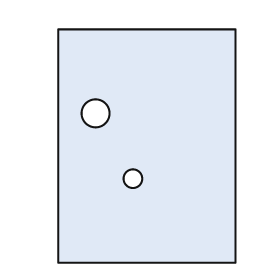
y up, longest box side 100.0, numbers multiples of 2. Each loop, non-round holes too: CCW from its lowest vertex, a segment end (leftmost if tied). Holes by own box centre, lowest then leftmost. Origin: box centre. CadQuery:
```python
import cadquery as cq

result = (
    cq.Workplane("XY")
    .moveTo(-38.0, -50.0)
    .lineTo(38.0, -50.0)
    .lineTo(38.0, 50.0)
    .lineTo(-38.0, 50.0)
    .close()
    .moveTo(-6.0, -14.0)
    .circle(4.0)
    .moveTo(-22.0, 14.0)
    .circle(6.0)
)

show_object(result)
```